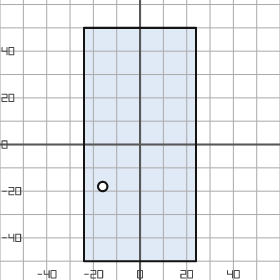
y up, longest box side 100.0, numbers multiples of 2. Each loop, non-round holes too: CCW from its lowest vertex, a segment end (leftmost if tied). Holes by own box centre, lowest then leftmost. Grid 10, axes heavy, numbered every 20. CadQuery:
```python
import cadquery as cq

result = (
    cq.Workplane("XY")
    .moveTo(-24.0, -50.0)
    .lineTo(24.0, -50.0)
    .lineTo(24.0, 50.0)
    .lineTo(-24.0, 50.0)
    .close()
    .moveTo(-16.0, -18.0)
    .circle(2.0)
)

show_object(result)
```